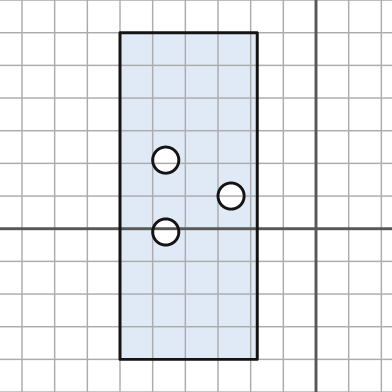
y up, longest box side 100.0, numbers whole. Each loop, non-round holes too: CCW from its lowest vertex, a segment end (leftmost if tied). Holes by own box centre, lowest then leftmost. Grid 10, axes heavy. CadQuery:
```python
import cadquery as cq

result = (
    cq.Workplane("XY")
    .moveTo(-60.0, -40.0)
    .lineTo(-18.0, -40.0)
    .lineTo(-18.0, 60.0)
    .lineTo(-60.0, 60.0)
    .close()
    .moveTo(-46.0, -1.0)
    .circle(4.0)
    .moveTo(-26.0, 10.0)
    .circle(4.0)
    .moveTo(-46.0, 21.0)
    .circle(4.0)
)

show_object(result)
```